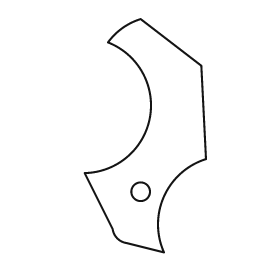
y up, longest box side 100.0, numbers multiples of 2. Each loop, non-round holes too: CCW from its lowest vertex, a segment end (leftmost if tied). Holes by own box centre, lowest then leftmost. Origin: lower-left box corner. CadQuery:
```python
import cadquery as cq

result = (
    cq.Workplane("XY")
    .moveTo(34.0, 0.0)
    .threePointArc((34.0, 24.0), (52.0, 40.0))
    .lineTo(50.0, 80.0)
    .lineTo(24.0, 100.0)
    .threePointArc((16.0, 96.0), (10.0, 90.0))
    .threePointArc((28.0, 58.0), (0.0, 34.0))
    .lineTo(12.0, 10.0)
    .threePointArc((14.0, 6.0), (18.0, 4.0))
    .close()
    .moveTo(24.0, 26.0)
    .circle(4.0)
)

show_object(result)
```